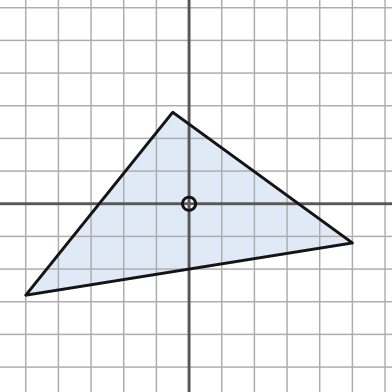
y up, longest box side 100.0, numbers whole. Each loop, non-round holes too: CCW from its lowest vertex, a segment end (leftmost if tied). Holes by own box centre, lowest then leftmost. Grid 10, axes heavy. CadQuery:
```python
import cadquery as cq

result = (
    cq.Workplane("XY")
    .moveTo(-50.0, -28.0)
    .lineTo(50.0, -12.0)
    .lineTo(-5.0, 28.0)
    .close()
    .moveTo(0.0, 0.0)
    .circle(2.0)
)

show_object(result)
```